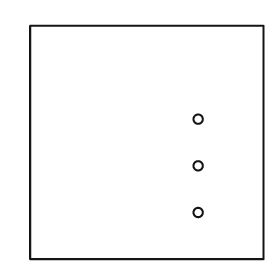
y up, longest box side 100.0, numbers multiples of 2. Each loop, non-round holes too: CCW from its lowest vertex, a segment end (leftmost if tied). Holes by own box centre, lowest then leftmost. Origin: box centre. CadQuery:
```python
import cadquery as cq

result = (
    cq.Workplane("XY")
    .moveTo(-50.0, -50.0)
    .lineTo(50.0, -50.0)
    .lineTo(50.0, 50.0)
    .lineTo(-50.0, 50.0)
    .close()
    .moveTo(22.0, -30.0)
    .circle(2.0)
    .moveTo(22.0, -10.0)
    .circle(2.0)
    .moveTo(22.0, 10.0)
    .circle(2.0)
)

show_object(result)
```